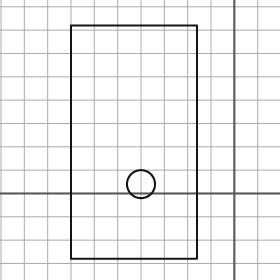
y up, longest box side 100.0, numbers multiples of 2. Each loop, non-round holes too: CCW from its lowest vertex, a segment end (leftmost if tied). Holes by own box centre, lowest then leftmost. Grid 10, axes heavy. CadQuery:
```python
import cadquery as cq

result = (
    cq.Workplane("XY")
    .moveTo(-70.0, -28.0)
    .lineTo(-16.0, -28.0)
    .lineTo(-16.0, 72.0)
    .lineTo(-70.0, 72.0)
    .close()
    .moveTo(-40.0, 4.0)
    .circle(6.0)
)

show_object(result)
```